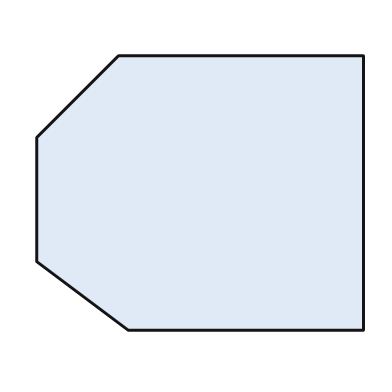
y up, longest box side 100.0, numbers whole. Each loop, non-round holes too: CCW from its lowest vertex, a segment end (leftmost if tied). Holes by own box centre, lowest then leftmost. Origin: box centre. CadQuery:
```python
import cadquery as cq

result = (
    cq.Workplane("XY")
    .moveTo(-22.0, -42.0)
    .lineTo(50.0, -42.0)
    .lineTo(50.0, 42.0)
    .lineTo(-25.0, 42.0)
    .lineTo(-50.0, 17.0)
    .lineTo(-50.0, -21.0)
    .close()
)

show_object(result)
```